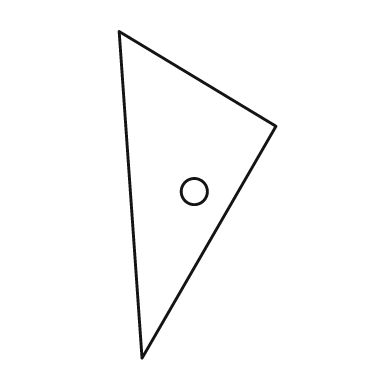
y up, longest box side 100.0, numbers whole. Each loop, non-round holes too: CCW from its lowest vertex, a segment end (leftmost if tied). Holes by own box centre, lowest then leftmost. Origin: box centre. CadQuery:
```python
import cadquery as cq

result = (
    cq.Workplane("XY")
    .moveTo(-17.0, -50.0)
    .lineTo(24.0, 21.0)
    .lineTo(-24.0, 50.0)
    .close()
    .moveTo(-1.0, 1.0)
    .circle(4.0)
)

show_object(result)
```